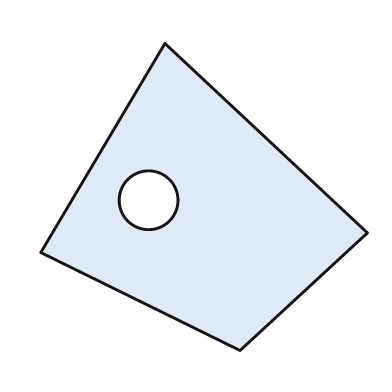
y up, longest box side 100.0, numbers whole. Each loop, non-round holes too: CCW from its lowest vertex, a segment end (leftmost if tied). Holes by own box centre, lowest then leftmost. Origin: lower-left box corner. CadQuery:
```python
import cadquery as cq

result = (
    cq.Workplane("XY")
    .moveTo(61.0, 0.0)
    .lineTo(100.0, 36.0)
    .lineTo(38.0, 94.0)
    .lineTo(0.0, 30.0)
    .close()
    .moveTo(33.0, 46.0)
    .circle(9.0)
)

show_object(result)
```